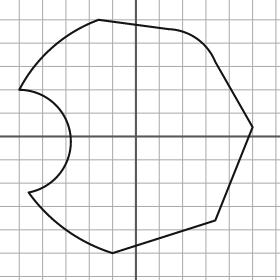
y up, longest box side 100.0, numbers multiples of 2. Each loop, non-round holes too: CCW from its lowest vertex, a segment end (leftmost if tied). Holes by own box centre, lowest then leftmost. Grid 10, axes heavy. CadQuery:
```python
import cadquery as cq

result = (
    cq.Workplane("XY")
    .moveTo(-10.0, -50.0)
    .lineTo(34.0, -36.0)
    .lineTo(50.0, 4.0)
    .lineTo(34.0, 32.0)
    .threePointArc((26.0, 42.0), (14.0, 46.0))
    .lineTo(-16.0, 50.0)
    .threePointArc((-36.0, 38.0), (-50.0, 20.0))
    .threePointArc((-28.0, 0.0), (-46.0, -24.0))
    .threePointArc((-30.0, -40.0), (-10.0, -50.0))
    .close()
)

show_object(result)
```